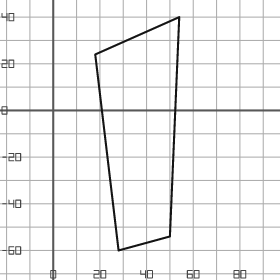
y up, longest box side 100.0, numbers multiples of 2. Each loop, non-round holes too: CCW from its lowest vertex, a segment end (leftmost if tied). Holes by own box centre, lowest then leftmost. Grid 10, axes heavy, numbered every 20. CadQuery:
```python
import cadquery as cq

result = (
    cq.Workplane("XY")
    .moveTo(28.0, -60.0)
    .lineTo(50.0, -54.0)
    .lineTo(54.0, 40.0)
    .lineTo(18.0, 24.0)
    .close()
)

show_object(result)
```